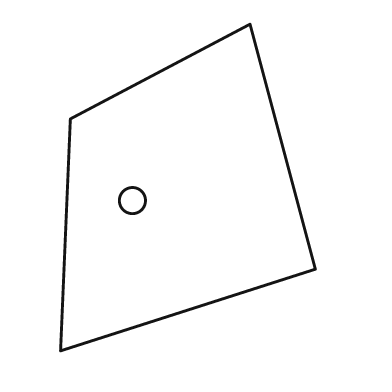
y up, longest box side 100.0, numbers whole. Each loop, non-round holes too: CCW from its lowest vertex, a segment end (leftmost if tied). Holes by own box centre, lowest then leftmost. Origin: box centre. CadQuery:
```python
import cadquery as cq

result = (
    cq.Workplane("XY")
    .moveTo(-39.0, -50.0)
    .lineTo(39.0, -25.0)
    .lineTo(19.0, 50.0)
    .lineTo(-36.0, 21.0)
    .close()
    .moveTo(-17.0, -4.0)
    .circle(4.0)
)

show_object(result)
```